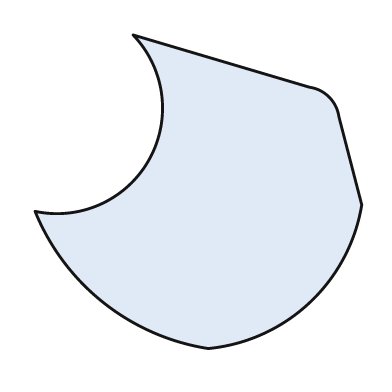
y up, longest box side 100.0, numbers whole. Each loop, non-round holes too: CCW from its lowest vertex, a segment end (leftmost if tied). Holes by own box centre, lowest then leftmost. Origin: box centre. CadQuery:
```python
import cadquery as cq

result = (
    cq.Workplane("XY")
    .moveTo(3.0, -48.0)
    .threePointArc((34.0, -34.0), (50.0, -4.0))
    .lineTo(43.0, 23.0)
    .threePointArc((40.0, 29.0), (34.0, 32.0))
    .lineTo(-20.0, 48.0)
    .threePointArc((-15.0, 10.0), (-50.0, -6.0))
    .threePointArc((-29.0, -34.0), (3.0, -48.0))
    .close()
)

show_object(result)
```